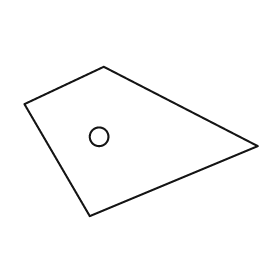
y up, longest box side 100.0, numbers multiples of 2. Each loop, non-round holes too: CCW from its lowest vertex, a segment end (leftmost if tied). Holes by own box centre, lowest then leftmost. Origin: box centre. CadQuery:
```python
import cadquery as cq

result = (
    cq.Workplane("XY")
    .moveTo(-22.0, -32.0)
    .lineTo(50.0, -2.0)
    .lineTo(-16.0, 32.0)
    .lineTo(-50.0, 16.0)
    .close()
    .moveTo(-18.0, 2.0)
    .circle(4.0)
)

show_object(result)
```